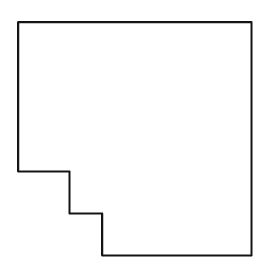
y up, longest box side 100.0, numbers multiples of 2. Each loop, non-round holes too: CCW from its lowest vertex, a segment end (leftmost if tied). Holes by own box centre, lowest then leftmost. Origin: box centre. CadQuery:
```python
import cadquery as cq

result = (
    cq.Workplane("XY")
    .moveTo(-14.0, -50.0)
    .lineTo(50.0, -50.0)
    .lineTo(50.0, 50.0)
    .lineTo(-50.0, 50.0)
    .lineTo(-50.0, -14.0)
    .lineTo(-28.0, -14.0)
    .lineTo(-28.0, -32.0)
    .lineTo(-14.0, -32.0)
    .close()
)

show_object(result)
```